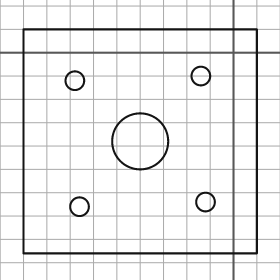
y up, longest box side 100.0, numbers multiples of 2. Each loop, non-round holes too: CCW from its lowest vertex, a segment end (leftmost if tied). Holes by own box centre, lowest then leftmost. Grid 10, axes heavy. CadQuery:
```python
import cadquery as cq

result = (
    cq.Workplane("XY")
    .moveTo(-90.0, -86.0)
    .lineTo(10.0, -86.0)
    .lineTo(10.0, 10.0)
    .lineTo(-90.0, 10.0)
    .close()
    .moveTo(-66.0, -66.0)
    .circle(4.0)
    .moveTo(-12.0, -64.0)
    .circle(4.0)
    .moveTo(-40.0, -38.0)
    .circle(12.0)
    .moveTo(-68.0, -12.0)
    .circle(4.0)
    .moveTo(-14.0, -10.0)
    .circle(4.0)
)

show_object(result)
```